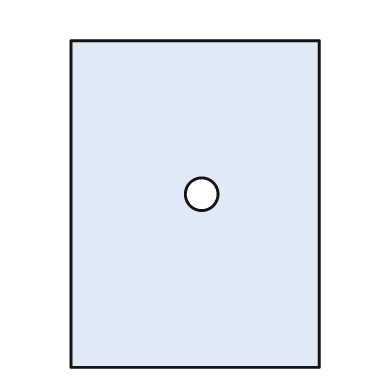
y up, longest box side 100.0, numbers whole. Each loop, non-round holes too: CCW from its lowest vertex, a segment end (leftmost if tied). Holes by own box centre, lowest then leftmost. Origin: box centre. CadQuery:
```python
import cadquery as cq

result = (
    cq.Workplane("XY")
    .moveTo(-38.0, -50.0)
    .lineTo(38.0, -50.0)
    .lineTo(38.0, 50.0)
    .lineTo(-38.0, 50.0)
    .close()
    .moveTo(2.0, 3.0)
    .circle(5.0)
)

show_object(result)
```